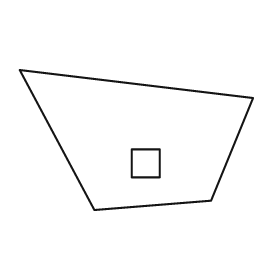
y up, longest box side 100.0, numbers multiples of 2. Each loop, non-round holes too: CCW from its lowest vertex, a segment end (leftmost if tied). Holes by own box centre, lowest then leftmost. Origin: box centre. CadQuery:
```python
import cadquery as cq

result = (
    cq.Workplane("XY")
    .moveTo(-18.0, -30.0)
    .lineTo(32.0, -26.0)
    .lineTo(50.0, 18.0)
    .lineTo(-50.0, 30.0)
    .close()
    .moveTo(-2.0, -16.0)
    .lineTo(10.0, -16.0)
    .lineTo(10.0, -4.0)
    .lineTo(-2.0, -4.0)
    .close()
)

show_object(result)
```